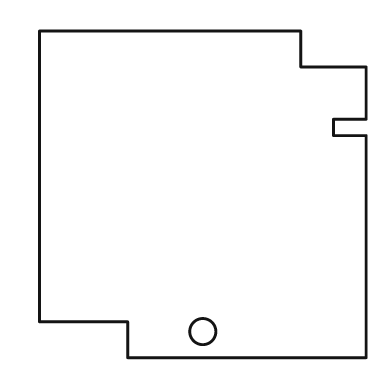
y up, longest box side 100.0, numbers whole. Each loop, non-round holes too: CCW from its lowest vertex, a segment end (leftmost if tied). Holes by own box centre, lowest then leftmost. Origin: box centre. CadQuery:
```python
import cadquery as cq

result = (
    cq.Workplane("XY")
    .moveTo(-23.0, -50.0)
    .lineTo(50.0, -50.0)
    .lineTo(50.0, 18.0)
    .lineTo(40.0, 18.0)
    .lineTo(40.0, 23.0)
    .lineTo(50.0, 23.0)
    .lineTo(50.0, 39.0)
    .lineTo(30.0, 39.0)
    .lineTo(30.0, 50.0)
    .lineTo(-50.0, 50.0)
    .lineTo(-50.0, -39.0)
    .lineTo(-23.0, -39.0)
    .close()
    .moveTo(0.0, -42.0)
    .circle(4.0)
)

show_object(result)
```